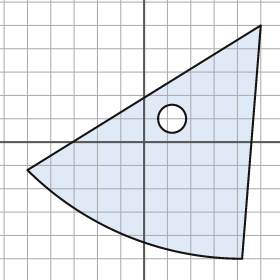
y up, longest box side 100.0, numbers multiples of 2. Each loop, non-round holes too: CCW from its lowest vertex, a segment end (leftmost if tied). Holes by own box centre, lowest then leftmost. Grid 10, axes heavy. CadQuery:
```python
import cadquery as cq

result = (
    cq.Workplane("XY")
    .moveTo(42.0, -50.0)
    .lineTo(50.0, 50.0)
    .lineTo(-50.0, -12.0)
    .threePointArc((-8.0, -40.0), (42.0, -50.0))
    .close()
    .moveTo(12.0, 10.0)
    .circle(6.0)
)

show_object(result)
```